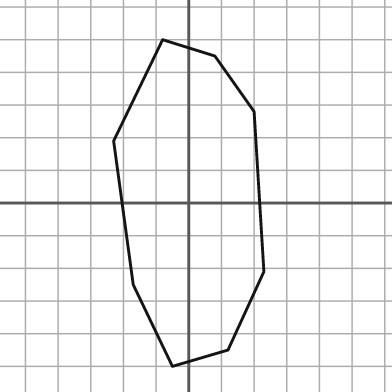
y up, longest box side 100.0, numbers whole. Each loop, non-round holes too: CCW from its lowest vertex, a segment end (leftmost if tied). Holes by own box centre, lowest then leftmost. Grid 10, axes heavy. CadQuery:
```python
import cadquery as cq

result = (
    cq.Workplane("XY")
    .moveTo(-5.0, -50.0)
    .lineTo(12.0, -45.0)
    .lineTo(23.0, -21.0)
    .lineTo(20.0, 28.0)
    .lineTo(8.0, 45.0)
    .lineTo(-8.0, 50.0)
    .lineTo(-23.0, 19.0)
    .lineTo(-17.0, -25.0)
    .close()
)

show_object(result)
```